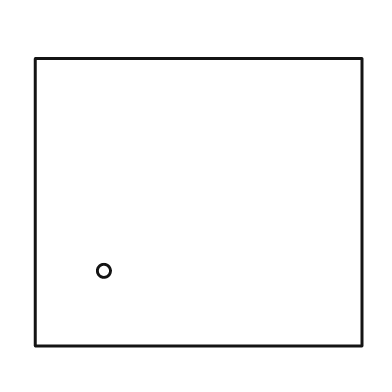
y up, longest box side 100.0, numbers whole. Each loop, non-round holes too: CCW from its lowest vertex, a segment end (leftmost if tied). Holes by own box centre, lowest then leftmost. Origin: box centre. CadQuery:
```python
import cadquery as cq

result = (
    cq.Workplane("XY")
    .moveTo(-50.0, -44.0)
    .lineTo(50.0, -44.0)
    .lineTo(50.0, 44.0)
    .lineTo(-50.0, 44.0)
    .close()
    .moveTo(-29.0, -21.0)
    .circle(2.0)
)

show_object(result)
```